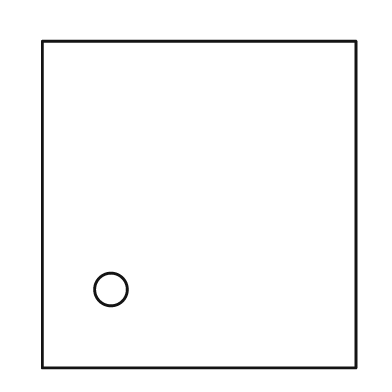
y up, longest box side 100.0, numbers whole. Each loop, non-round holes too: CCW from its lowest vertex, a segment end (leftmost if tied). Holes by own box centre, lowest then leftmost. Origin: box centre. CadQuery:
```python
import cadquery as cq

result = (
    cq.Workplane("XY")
    .moveTo(-48.0, -50.0)
    .lineTo(48.0, -50.0)
    .lineTo(48.0, 50.0)
    .lineTo(-48.0, 50.0)
    .close()
    .moveTo(-27.0, -26.0)
    .circle(5.0)
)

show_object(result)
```